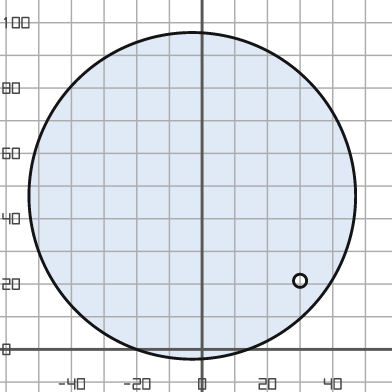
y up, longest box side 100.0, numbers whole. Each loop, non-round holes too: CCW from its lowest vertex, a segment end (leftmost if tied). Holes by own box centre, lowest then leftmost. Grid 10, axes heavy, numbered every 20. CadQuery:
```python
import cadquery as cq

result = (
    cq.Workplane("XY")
    .moveTo(-3.0, 47.0)
    .circle(50.0)
    .moveTo(30.0, 21.0)
    .circle(2.0)
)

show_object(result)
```